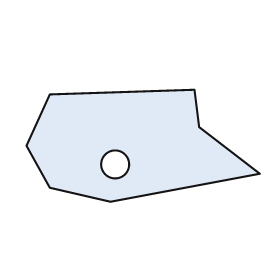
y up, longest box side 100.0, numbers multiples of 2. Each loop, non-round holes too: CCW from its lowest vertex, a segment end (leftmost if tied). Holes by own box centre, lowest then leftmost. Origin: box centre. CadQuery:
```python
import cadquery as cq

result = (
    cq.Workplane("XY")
    .moveTo(-14.0, -24.0)
    .lineTo(50.0, -12.0)
    .lineTo(24.0, 8.0)
    .lineTo(22.0, 24.0)
    .lineTo(-40.0, 22.0)
    .lineTo(-50.0, 0.0)
    .lineTo(-40.0, -18.0)
    .close()
    .moveTo(-12.0, -8.0)
    .circle(6.0)
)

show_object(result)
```